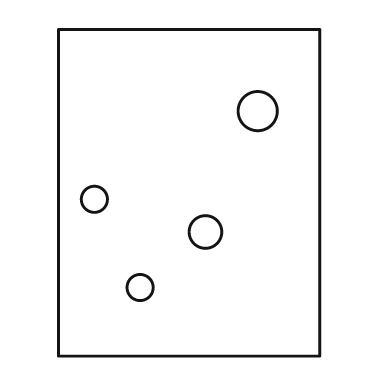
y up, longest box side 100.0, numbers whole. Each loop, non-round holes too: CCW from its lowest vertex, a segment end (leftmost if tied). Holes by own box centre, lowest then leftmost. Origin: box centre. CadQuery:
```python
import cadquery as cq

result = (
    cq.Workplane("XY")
    .moveTo(-40.0, -50.0)
    .lineTo(40.0, -50.0)
    .lineTo(40.0, 50.0)
    .lineTo(-40.0, 50.0)
    .close()
    .moveTo(-15.0, -29.0)
    .circle(4.0)
    .moveTo(5.0, -12.0)
    .circle(5.0)
    .moveTo(-29.0, -2.0)
    .circle(4.0)
    .moveTo(21.0, 25.0)
    .circle(6.0)
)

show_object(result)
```